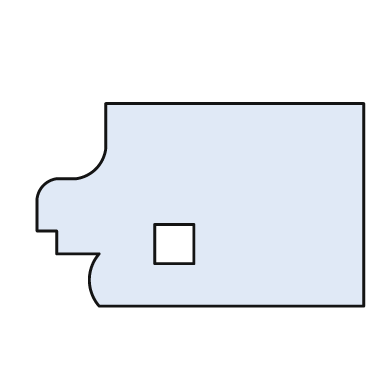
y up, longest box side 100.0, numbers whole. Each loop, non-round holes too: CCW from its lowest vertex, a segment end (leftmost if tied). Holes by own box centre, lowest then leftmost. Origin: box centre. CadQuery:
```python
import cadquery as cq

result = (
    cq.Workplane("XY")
    .moveTo(-31.0, -31.0)
    .lineTo(50.0, -31.0)
    .lineTo(50.0, 31.0)
    .lineTo(-29.0, 31.0)
    .lineTo(-29.0, 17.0)
    .threePointArc((-32.0, 11.0), (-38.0, 8.0))
    .lineTo(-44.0, 8.0)
    .threePointArc((-48.0, 6.0), (-50.0, 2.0))
    .lineTo(-50.0, -8.0)
    .lineTo(-44.0, -8.0)
    .lineTo(-44.0, -15.0)
    .lineTo(-31.0, -15.0)
    .threePointArc((-34.0, -23.0), (-31.0, -31.0))
    .close()
    .moveTo(-14.0, -18.0)
    .lineTo(-2.0, -18.0)
    .lineTo(-2.0, -6.0)
    .lineTo(-14.0, -6.0)
    .close()
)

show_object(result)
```